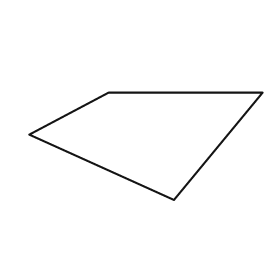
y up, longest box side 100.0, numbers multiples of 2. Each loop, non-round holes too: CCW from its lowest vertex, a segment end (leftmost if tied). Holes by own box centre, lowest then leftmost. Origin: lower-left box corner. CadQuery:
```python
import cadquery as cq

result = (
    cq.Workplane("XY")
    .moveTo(62.0, 0.0)
    .lineTo(100.0, 46.0)
    .lineTo(34.0, 46.0)
    .lineTo(0.0, 28.0)
    .close()
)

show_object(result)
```